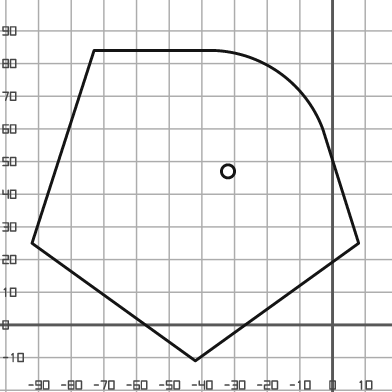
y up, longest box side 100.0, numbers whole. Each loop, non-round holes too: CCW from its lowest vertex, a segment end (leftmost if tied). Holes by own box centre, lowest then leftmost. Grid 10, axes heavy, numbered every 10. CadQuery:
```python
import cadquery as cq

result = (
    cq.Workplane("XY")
    .moveTo(-42.0, -11.0)
    .lineTo(8.0, 25.0)
    .lineTo(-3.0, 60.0)
    .threePointArc((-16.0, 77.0), (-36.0, 84.0))
    .lineTo(-73.0, 84.0)
    .lineTo(-92.0, 25.0)
    .close()
    .moveTo(-32.0, 47.0)
    .circle(2.0)
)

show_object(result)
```